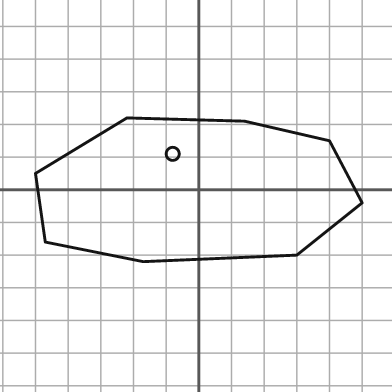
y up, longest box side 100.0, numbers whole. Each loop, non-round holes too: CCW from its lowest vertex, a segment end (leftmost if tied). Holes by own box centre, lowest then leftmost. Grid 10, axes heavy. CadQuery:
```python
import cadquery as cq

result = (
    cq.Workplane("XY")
    .moveTo(-17.0, -22.0)
    .lineTo(30.0, -20.0)
    .lineTo(50.0, -4.0)
    .lineTo(40.0, 15.0)
    .lineTo(14.0, 21.0)
    .lineTo(-22.0, 22.0)
    .lineTo(-50.0, 5.0)
    .lineTo(-47.0, -16.0)
    .close()
    .moveTo(-8.0, 11.0)
    .circle(2.0)
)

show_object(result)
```